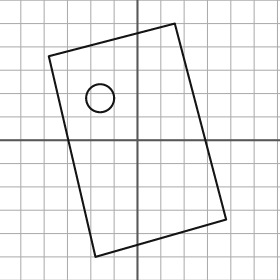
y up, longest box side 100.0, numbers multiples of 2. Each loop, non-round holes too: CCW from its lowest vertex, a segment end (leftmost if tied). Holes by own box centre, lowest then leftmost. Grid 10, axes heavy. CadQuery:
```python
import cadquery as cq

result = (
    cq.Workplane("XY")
    .moveTo(-18.0, -50.0)
    .lineTo(38.0, -34.0)
    .lineTo(16.0, 50.0)
    .lineTo(-38.0, 36.0)
    .close()
    .moveTo(-16.0, 18.0)
    .circle(6.0)
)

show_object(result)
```